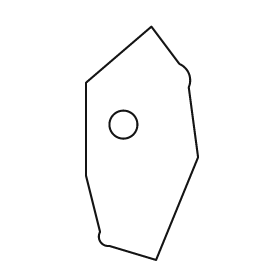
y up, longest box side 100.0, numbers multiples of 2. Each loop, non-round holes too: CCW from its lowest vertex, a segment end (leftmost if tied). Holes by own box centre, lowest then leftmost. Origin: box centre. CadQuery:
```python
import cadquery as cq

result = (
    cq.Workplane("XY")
    .moveTo(6.0, -50.0)
    .lineTo(24.0, -6.0)
    .lineTo(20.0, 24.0)
    .threePointArc((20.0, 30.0), (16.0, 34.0))
    .lineTo(4.0, 50.0)
    .lineTo(-24.0, 26.0)
    .lineTo(-24.0, -14.0)
    .lineTo(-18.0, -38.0)
    .threePointArc((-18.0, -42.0), (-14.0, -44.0))
    .close()
    .moveTo(-8.0, 8.0)
    .circle(6.0)
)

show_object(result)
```